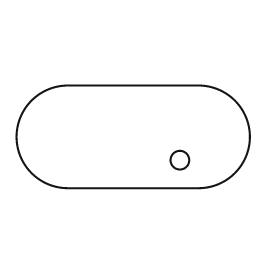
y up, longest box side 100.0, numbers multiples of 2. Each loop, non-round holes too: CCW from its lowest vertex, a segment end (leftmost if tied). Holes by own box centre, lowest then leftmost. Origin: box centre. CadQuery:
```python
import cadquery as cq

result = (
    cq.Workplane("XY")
    .moveTo(-28.0, -22.0)
    .lineTo(28.0, -22.0)
    .threePointArc((50.0, 0.0), (28.0, 22.0))
    .lineTo(-28.0, 22.0)
    .threePointArc((-50.0, 0.0), (-28.0, -22.0))
    .close()
    .moveTo(20.0, -10.0)
    .circle(4.0)
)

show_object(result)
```